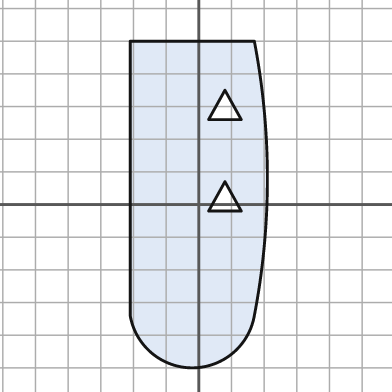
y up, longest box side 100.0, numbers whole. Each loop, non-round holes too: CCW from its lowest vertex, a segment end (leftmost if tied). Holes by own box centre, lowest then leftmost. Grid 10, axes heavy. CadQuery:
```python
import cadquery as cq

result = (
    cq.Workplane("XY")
    .moveTo(-21.0, -34.0)
    .threePointArc((-2.0, -50.0), (17.0, -34.0))
    .threePointArc((21.0, 8.0), (17.0, 50.0))
    .lineTo(-21.0, 50.0)
    .close()
    .moveTo(3.0, -2.0)
    .lineTo(13.0, -2.0)
    .lineTo(8.0, 7.0)
    .close()
    .moveTo(3.0, 26.0)
    .lineTo(13.0, 26.0)
    .lineTo(8.0, 35.0)
    .close()
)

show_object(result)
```